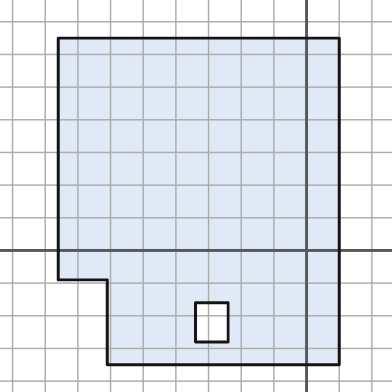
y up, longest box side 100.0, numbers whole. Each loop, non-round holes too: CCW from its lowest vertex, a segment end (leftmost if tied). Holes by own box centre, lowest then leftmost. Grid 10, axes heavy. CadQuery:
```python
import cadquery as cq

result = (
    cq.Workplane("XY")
    .moveTo(-61.0, -35.0)
    .lineTo(10.0, -35.0)
    .lineTo(10.0, 65.0)
    .lineTo(-76.0, 65.0)
    .lineTo(-76.0, -9.0)
    .lineTo(-61.0, -9.0)
    .close()
    .moveTo(-34.0, -28.0)
    .lineTo(-24.0, -28.0)
    .lineTo(-24.0, -16.0)
    .lineTo(-34.0, -16.0)
    .close()
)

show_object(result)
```